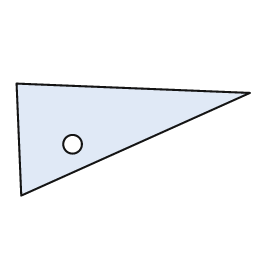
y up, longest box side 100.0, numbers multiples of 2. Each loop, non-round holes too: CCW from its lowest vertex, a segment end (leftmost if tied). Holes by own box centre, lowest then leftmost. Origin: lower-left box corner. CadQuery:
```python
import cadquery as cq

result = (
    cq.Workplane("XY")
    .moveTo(2.0, 0.0)
    .lineTo(100.0, 44.0)
    .lineTo(0.0, 48.0)
    .close()
    .moveTo(24.0, 22.0)
    .circle(4.0)
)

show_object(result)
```